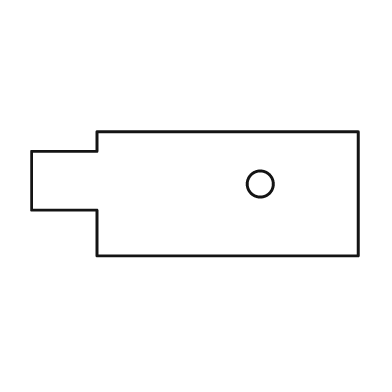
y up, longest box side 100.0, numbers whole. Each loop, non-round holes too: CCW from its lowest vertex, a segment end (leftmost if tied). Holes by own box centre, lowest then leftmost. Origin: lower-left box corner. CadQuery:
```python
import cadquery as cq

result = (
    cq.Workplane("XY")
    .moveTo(20.0, 0.0)
    .lineTo(100.0, 0.0)
    .lineTo(100.0, 38.0)
    .lineTo(20.0, 38.0)
    .lineTo(20.0, 32.0)
    .lineTo(0.0, 32.0)
    .lineTo(0.0, 14.0)
    .lineTo(20.0, 14.0)
    .close()
    .moveTo(70.0, 22.0)
    .circle(4.0)
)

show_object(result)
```